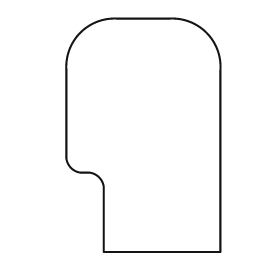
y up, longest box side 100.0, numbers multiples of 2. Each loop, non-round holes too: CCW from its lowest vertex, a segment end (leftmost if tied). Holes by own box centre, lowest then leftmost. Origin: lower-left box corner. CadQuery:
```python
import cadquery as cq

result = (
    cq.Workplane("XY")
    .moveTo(16.0, 0.0)
    .lineTo(66.0, 0.0)
    .lineTo(66.0, 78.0)
    .threePointArc((60.0, 94.0), (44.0, 100.0))
    .lineTo(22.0, 100.0)
    .threePointArc((6.0, 94.0), (0.0, 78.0))
    .lineTo(0.0, 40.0)
    .threePointArc((2.0, 36.0), (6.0, 34.0))
    .lineTo(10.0, 34.0)
    .threePointArc((14.0, 32.0), (16.0, 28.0))
    .close()
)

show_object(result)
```